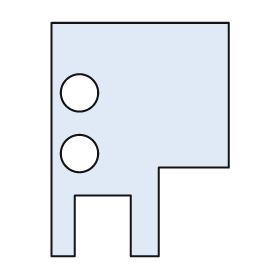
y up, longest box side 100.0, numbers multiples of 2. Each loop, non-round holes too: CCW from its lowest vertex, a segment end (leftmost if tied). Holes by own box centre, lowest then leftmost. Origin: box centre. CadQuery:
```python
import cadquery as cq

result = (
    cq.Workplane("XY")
    .moveTo(-38.0, -50.0)
    .lineTo(-28.0, -50.0)
    .lineTo(-28.0, -24.0)
    .lineTo(-4.0, -24.0)
    .lineTo(-4.0, -50.0)
    .lineTo(8.0, -50.0)
    .lineTo(8.0, -12.0)
    .lineTo(38.0, -12.0)
    .lineTo(38.0, 50.0)
    .lineTo(-38.0, 50.0)
    .close()
    .moveTo(-26.0, -6.0)
    .circle(8.0)
    .moveTo(-26.0, 20.0)
    .circle(8.0)
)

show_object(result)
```